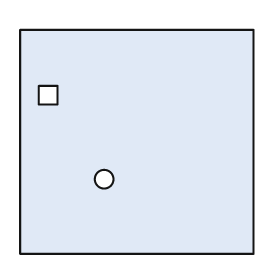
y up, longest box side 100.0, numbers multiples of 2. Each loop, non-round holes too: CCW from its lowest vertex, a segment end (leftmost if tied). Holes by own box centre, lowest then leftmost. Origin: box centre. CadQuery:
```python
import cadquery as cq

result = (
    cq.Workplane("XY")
    .moveTo(-50.0, -48.0)
    .lineTo(50.0, -48.0)
    .lineTo(50.0, 48.0)
    .lineTo(-50.0, 48.0)
    .close()
    .moveTo(-14.0, -16.0)
    .circle(4.0)
    .moveTo(-42.0, 16.0)
    .lineTo(-34.0, 16.0)
    .lineTo(-34.0, 24.0)
    .lineTo(-42.0, 24.0)
    .close()
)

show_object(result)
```